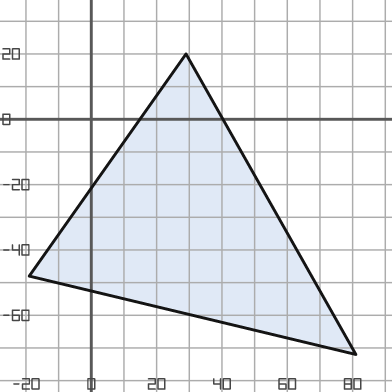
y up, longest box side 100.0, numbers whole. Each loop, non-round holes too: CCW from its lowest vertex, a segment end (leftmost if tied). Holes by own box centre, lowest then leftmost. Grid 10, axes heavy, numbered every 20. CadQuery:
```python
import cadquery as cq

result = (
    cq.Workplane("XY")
    .moveTo(81.0, -72.0)
    .lineTo(29.0, 20.0)
    .lineTo(-19.0, -48.0)
    .close()
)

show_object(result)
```